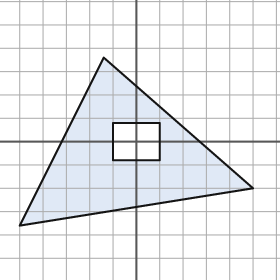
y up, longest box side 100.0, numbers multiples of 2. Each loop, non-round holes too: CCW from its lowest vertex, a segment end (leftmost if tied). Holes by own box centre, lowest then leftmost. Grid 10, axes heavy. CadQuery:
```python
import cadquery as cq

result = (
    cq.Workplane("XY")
    .moveTo(-50.0, -36.0)
    .lineTo(50.0, -20.0)
    .lineTo(-14.0, 36.0)
    .close()
    .moveTo(-10.0, -8.0)
    .lineTo(10.0, -8.0)
    .lineTo(10.0, 8.0)
    .lineTo(-10.0, 8.0)
    .close()
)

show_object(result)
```